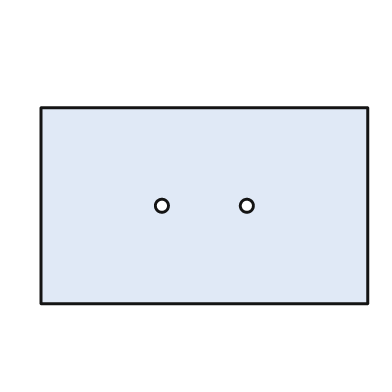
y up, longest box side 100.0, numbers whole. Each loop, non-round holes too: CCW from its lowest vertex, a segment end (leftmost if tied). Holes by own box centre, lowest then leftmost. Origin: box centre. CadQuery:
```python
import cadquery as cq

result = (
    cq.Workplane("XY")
    .moveTo(-50.0, -30.0)
    .lineTo(50.0, -30.0)
    .lineTo(50.0, 30.0)
    .lineTo(-50.0, 30.0)
    .close()
    .moveTo(-13.0, 0.0)
    .circle(2.0)
    .moveTo(13.0, 0.0)
    .circle(2.0)
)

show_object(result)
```